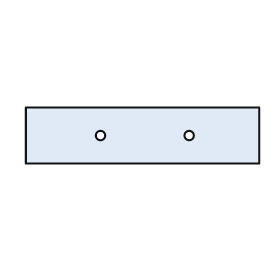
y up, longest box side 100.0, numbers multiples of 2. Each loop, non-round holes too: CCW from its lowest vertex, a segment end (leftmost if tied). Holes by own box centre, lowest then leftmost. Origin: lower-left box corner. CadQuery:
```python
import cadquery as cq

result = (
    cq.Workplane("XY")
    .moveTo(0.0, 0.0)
    .lineTo(100.0, 0.0)
    .lineTo(100.0, 24.0)
    .lineTo(0.0, 24.0)
    .close()
    .moveTo(32.0, 12.0)
    .circle(2.0)
    .moveTo(70.0, 12.0)
    .circle(2.0)
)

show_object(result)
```